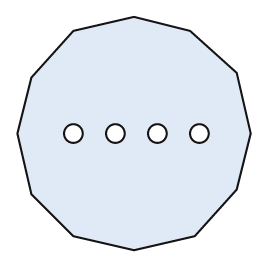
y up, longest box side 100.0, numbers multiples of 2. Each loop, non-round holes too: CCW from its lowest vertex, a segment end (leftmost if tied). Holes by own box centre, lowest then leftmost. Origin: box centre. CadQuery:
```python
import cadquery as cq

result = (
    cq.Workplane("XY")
    .moveTo(0.0, -50.0)
    .lineTo(26.0, -44.0)
    .lineTo(44.0, -24.0)
    .lineTo(50.0, 0.0)
    .lineTo(44.0, 26.0)
    .lineTo(24.0, 44.0)
    .lineTo(0.0, 50.0)
    .lineTo(-26.0, 44.0)
    .lineTo(-44.0, 24.0)
    .lineTo(-50.0, 0.0)
    .lineTo(-44.0, -26.0)
    .lineTo(-26.0, -44.0)
    .close()
    .moveTo(-26.0, 0.0)
    .circle(4.0)
    .moveTo(-8.0, 0.0)
    .circle(4.0)
    .moveTo(10.0, 0.0)
    .circle(4.0)
    .moveTo(28.0, 0.0)
    .circle(4.0)
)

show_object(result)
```